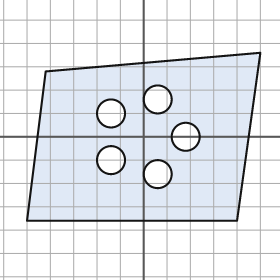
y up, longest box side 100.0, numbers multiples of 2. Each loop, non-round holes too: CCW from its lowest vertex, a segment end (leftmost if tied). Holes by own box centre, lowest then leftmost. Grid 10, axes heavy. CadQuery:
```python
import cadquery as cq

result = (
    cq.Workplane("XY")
    .moveTo(-50.0, -36.0)
    .lineTo(40.0, -36.0)
    .lineTo(50.0, 36.0)
    .lineTo(-42.0, 28.0)
    .close()
    .moveTo(6.0, -16.0)
    .circle(6.0)
    .moveTo(-14.0, -10.0)
    .circle(6.0)
    .moveTo(18.0, 0.0)
    .circle(6.0)
    .moveTo(-14.0, 10.0)
    .circle(6.0)
    .moveTo(6.0, 16.0)
    .circle(6.0)
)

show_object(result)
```